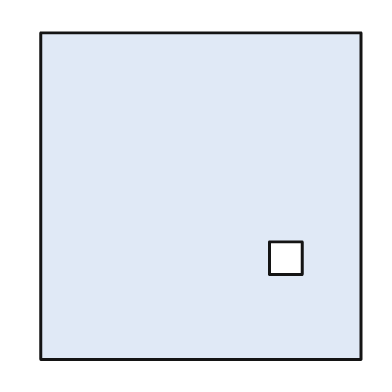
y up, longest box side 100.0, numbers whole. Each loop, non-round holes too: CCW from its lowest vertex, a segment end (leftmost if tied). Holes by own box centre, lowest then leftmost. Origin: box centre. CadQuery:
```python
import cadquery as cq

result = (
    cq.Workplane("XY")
    .moveTo(-49.0, -50.0)
    .lineTo(49.0, -50.0)
    .lineTo(49.0, 50.0)
    .lineTo(-49.0, 50.0)
    .close()
    .moveTo(21.0, -24.0)
    .lineTo(31.0, -24.0)
    .lineTo(31.0, -14.0)
    .lineTo(21.0, -14.0)
    .close()
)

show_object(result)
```